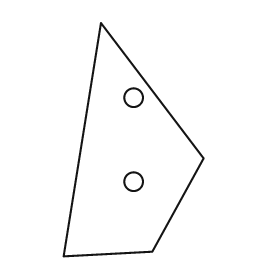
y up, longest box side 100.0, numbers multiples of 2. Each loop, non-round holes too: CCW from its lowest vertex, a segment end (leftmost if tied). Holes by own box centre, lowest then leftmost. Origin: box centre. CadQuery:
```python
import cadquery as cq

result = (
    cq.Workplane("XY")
    .moveTo(-30.0, -50.0)
    .lineTo(8.0, -48.0)
    .lineTo(30.0, -8.0)
    .lineTo(-14.0, 50.0)
    .close()
    .moveTo(0.0, -18.0)
    .circle(4.0)
    .moveTo(0.0, 18.0)
    .circle(4.0)
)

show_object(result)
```